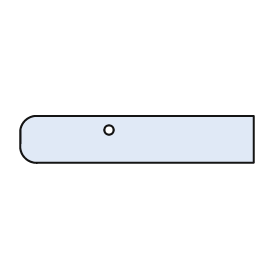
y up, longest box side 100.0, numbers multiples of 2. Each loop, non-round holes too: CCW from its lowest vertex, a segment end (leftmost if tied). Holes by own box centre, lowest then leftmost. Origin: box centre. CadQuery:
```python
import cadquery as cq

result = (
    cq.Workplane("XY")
    .moveTo(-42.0, -10.0)
    .lineTo(50.0, -10.0)
    .lineTo(50.0, 10.0)
    .lineTo(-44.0, 10.0)
    .threePointArc((-48.0, 8.0), (-50.0, 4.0))
    .lineTo(-50.0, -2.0)
    .threePointArc((-48.0, -8.0), (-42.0, -10.0))
    .close()
    .moveTo(-12.0, 4.0)
    .circle(2.0)
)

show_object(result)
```